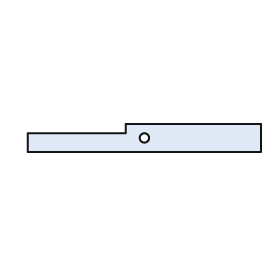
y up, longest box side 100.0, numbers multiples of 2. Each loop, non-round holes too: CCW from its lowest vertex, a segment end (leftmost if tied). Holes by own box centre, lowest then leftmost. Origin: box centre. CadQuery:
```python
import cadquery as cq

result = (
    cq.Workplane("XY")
    .moveTo(-50.0, -6.0)
    .lineTo(50.0, -6.0)
    .lineTo(50.0, 6.0)
    .lineTo(-8.0, 6.0)
    .lineTo(-8.0, 2.0)
    .lineTo(-50.0, 2.0)
    .close()
    .moveTo(0.0, 0.0)
    .circle(2.0)
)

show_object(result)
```